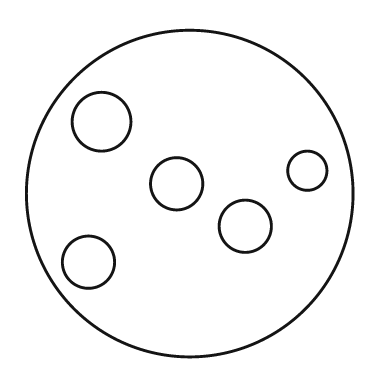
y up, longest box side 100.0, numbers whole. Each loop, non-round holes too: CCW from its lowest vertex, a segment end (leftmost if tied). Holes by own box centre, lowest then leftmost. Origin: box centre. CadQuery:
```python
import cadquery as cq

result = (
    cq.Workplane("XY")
    .moveTo(0.0, 0.0)
    .circle(50.0)
    .moveTo(-31.0, -21.0)
    .circle(8.0)
    .moveTo(17.0, -10.0)
    .circle(8.0)
    .moveTo(-4.0, 3.0)
    .circle(8.0)
    .moveTo(36.0, 7.0)
    .circle(6.0)
    .moveTo(-27.0, 22.0)
    .circle(9.0)
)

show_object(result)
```